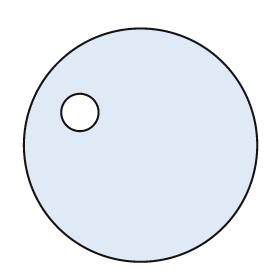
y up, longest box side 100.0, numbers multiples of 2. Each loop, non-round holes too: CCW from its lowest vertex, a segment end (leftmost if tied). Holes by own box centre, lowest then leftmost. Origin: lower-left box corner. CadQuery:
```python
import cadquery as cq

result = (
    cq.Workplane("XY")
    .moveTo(50.0, 50.0)
    .circle(50.0)
    .moveTo(24.0, 64.0)
    .circle(8.0)
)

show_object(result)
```